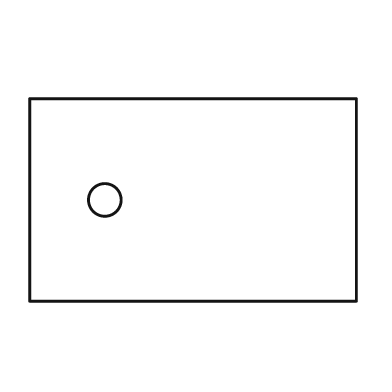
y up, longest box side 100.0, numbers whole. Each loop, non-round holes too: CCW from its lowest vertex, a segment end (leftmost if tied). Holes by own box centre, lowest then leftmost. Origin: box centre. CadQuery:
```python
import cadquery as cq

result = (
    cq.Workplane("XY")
    .moveTo(-50.0, -31.0)
    .lineTo(50.0, -31.0)
    .lineTo(50.0, 31.0)
    .lineTo(-50.0, 31.0)
    .close()
    .moveTo(-27.0, 0.0)
    .circle(5.0)
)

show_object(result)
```